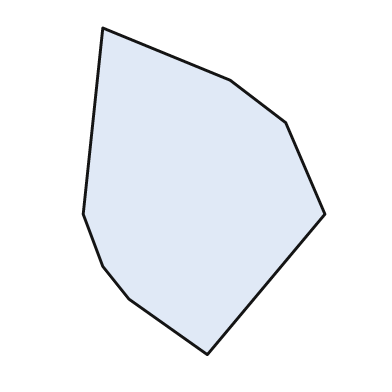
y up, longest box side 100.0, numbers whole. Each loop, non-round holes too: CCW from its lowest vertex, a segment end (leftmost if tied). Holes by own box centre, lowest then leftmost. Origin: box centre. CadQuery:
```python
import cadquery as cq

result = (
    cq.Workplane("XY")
    .moveTo(1.0, -50.0)
    .lineTo(37.0, -7.0)
    .lineTo(25.0, 21.0)
    .lineTo(8.0, 34.0)
    .lineTo(-31.0, 50.0)
    .lineTo(-37.0, -7.0)
    .lineTo(-31.0, -23.0)
    .lineTo(-23.0, -33.0)
    .close()
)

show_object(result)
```